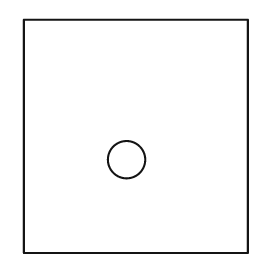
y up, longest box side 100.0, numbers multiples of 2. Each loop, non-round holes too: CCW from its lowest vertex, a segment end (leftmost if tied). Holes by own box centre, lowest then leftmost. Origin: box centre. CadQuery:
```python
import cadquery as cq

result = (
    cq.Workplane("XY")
    .moveTo(-48.0, -50.0)
    .lineTo(48.0, -50.0)
    .lineTo(48.0, 50.0)
    .lineTo(-48.0, 50.0)
    .close()
    .moveTo(-4.0, -10.0)
    .circle(8.0)
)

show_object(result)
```